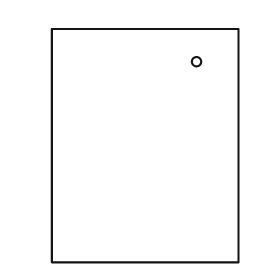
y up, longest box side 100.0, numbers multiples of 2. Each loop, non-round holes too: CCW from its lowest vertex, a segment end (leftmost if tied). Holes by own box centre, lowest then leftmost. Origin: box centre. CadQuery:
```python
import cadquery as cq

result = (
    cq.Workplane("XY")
    .moveTo(-40.0, -50.0)
    .lineTo(40.0, -50.0)
    .lineTo(40.0, 50.0)
    .lineTo(-40.0, 50.0)
    .close()
    .moveTo(22.0, 36.0)
    .circle(2.0)
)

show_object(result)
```